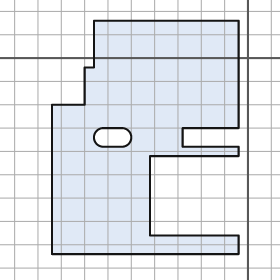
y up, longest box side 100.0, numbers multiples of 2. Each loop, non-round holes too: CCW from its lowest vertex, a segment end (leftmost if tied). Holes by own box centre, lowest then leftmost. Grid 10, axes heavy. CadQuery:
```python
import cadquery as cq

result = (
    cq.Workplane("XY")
    .moveTo(-84.0, -84.0)
    .lineTo(-4.0, -84.0)
    .lineTo(-4.0, -76.0)
    .lineTo(-42.0, -76.0)
    .lineTo(-42.0, -42.0)
    .lineTo(-4.0, -42.0)
    .lineTo(-4.0, -38.0)
    .lineTo(-28.0, -38.0)
    .lineTo(-28.0, -30.0)
    .lineTo(-4.0, -30.0)
    .lineTo(-4.0, 16.0)
    .lineTo(-66.0, 16.0)
    .lineTo(-66.0, -4.0)
    .lineTo(-70.0, -4.0)
    .lineTo(-70.0, -20.0)
    .lineTo(-84.0, -20.0)
    .close()
    .moveTo(-62.0, -38.0)
    .lineTo(-54.0, -38.0)
    .threePointArc((-50.0, -34.0), (-54.0, -30.0))
    .lineTo(-62.0, -30.0)
    .threePointArc((-66.0, -34.0), (-62.0, -38.0))
    .close()
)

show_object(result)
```